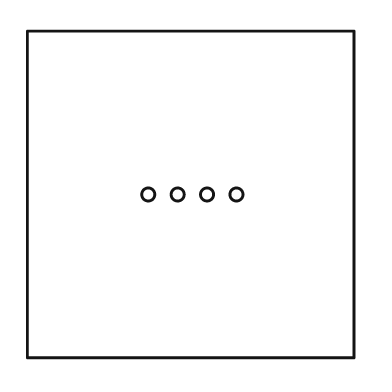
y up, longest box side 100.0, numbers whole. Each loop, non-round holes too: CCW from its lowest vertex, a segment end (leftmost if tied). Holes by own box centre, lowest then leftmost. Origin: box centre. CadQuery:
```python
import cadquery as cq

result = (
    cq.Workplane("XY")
    .moveTo(-50.0, -50.0)
    .lineTo(50.0, -50.0)
    .lineTo(50.0, 50.0)
    .lineTo(-50.0, 50.0)
    .close()
    .moveTo(-13.0, 0.0)
    .circle(2.0)
    .moveTo(-4.0, 0.0)
    .circle(2.0)
    .moveTo(5.0, 0.0)
    .circle(2.0)
    .moveTo(14.0, 0.0)
    .circle(2.0)
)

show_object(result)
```